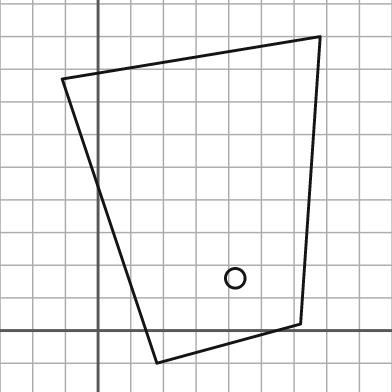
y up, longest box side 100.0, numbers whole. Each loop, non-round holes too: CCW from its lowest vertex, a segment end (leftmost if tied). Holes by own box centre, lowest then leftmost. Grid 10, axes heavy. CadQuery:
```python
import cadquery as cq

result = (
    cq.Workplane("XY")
    .moveTo(18.0, -10.0)
    .lineTo(62.0, 2.0)
    .lineTo(68.0, 90.0)
    .lineTo(-11.0, 77.0)
    .close()
    .moveTo(42.0, 16.0)
    .circle(3.0)
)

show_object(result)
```